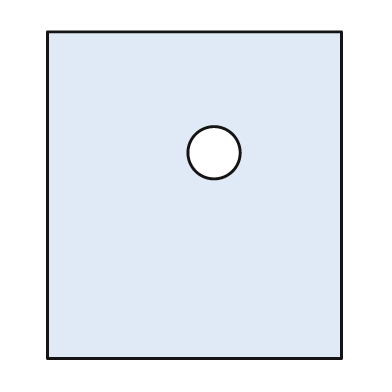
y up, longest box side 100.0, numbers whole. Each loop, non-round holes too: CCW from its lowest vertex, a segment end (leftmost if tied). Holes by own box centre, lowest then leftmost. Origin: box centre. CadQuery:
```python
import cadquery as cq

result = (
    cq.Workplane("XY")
    .moveTo(-45.0, -50.0)
    .lineTo(45.0, -50.0)
    .lineTo(45.0, 50.0)
    .lineTo(-45.0, 50.0)
    .close()
    .moveTo(6.0, 13.0)
    .circle(8.0)
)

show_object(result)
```